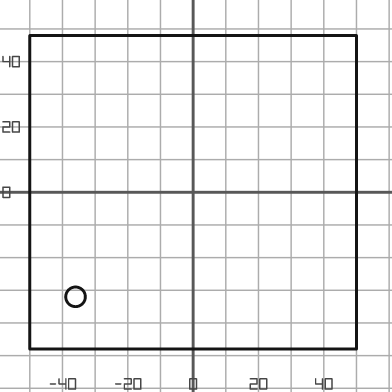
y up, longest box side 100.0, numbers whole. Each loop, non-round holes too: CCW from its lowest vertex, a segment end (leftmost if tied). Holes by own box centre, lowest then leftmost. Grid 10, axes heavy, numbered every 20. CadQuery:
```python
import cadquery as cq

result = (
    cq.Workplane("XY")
    .moveTo(-50.0, -48.0)
    .lineTo(50.0, -48.0)
    .lineTo(50.0, 48.0)
    .lineTo(-50.0, 48.0)
    .close()
    .moveTo(-36.0, -32.0)
    .circle(3.0)
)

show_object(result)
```